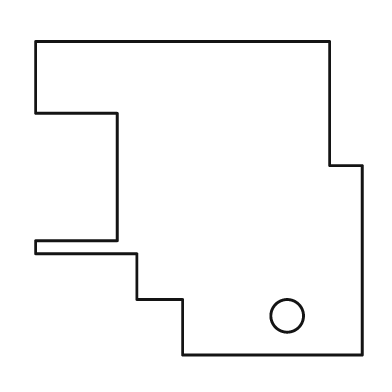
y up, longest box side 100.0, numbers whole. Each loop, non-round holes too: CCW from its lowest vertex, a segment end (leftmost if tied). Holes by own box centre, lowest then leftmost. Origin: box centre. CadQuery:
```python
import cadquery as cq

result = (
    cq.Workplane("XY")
    .moveTo(-5.0, -48.0)
    .lineTo(50.0, -48.0)
    .lineTo(50.0, 10.0)
    .lineTo(40.0, 10.0)
    .lineTo(40.0, 48.0)
    .lineTo(-50.0, 48.0)
    .lineTo(-50.0, 26.0)
    .lineTo(-25.0, 26.0)
    .lineTo(-25.0, -13.0)
    .lineTo(-50.0, -13.0)
    .lineTo(-50.0, -17.0)
    .lineTo(-19.0, -17.0)
    .lineTo(-19.0, -31.0)
    .lineTo(-5.0, -31.0)
    .close()
    .moveTo(27.0, -36.0)
    .circle(5.0)
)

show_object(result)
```